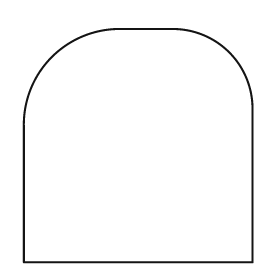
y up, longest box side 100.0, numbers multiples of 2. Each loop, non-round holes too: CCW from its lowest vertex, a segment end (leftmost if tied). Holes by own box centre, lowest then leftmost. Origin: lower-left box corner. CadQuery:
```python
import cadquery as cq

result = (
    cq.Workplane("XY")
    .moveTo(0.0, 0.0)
    .lineTo(98.0, 0.0)
    .lineTo(98.0, 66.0)
    .threePointArc((88.0, 90.0), (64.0, 100.0))
    .lineTo(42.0, 100.0)
    .threePointArc((12.0, 88.0), (0.0, 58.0))
    .close()
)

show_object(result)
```